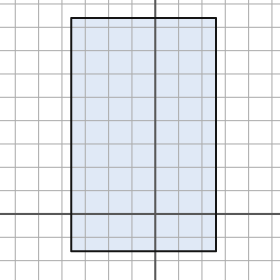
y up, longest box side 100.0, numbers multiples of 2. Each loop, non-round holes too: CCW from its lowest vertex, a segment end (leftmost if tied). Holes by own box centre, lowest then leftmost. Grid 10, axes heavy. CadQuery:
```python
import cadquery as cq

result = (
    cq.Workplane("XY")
    .moveTo(-36.0, -16.0)
    .lineTo(26.0, -16.0)
    .lineTo(26.0, 84.0)
    .lineTo(-36.0, 84.0)
    .close()
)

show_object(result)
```